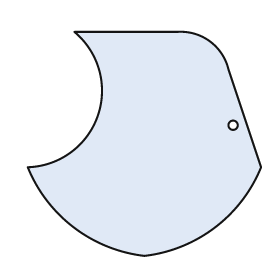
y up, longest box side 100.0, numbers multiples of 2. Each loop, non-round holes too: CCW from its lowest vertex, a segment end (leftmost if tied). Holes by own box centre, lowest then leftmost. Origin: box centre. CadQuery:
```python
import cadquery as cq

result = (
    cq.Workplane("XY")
    .moveTo(0.0, -48.0)
    .threePointArc((30.0, -36.0), (50.0, -10.0))
    .lineTo(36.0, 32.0)
    .threePointArc((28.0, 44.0), (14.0, 48.0))
    .lineTo(-30.0, 48.0)
    .threePointArc((-20.0, 12.0), (-50.0, -10.0))
    .threePointArc((-30.0, -36.0), (0.0, -48.0))
    .close()
    .moveTo(38.0, 8.0)
    .circle(2.0)
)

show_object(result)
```